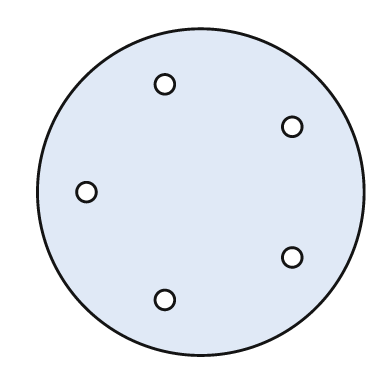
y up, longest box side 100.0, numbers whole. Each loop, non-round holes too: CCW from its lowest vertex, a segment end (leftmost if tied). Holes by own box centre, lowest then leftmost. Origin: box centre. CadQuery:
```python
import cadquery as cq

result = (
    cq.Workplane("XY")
    .moveTo(0.0, 0.0)
    .circle(50.0)
    .moveTo(-11.0, -33.0)
    .circle(3.0)
    .moveTo(28.0, -20.0)
    .circle(3.0)
    .moveTo(-35.0, 0.0)
    .circle(3.0)
    .moveTo(28.0, 20.0)
    .circle(3.0)
    .moveTo(-11.0, 33.0)
    .circle(3.0)
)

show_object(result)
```